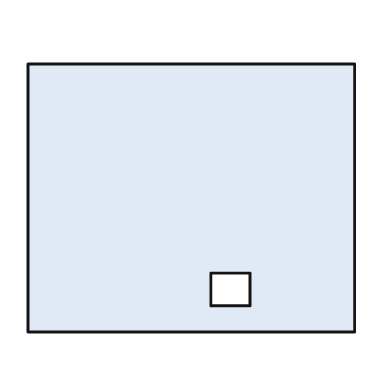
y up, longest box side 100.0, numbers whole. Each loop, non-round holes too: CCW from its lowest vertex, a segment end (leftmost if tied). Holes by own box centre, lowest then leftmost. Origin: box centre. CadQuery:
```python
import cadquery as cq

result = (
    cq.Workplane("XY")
    .moveTo(-50.0, -41.0)
    .lineTo(50.0, -41.0)
    .lineTo(50.0, 41.0)
    .lineTo(-50.0, 41.0)
    .close()
    .moveTo(6.0, -33.0)
    .lineTo(18.0, -33.0)
    .lineTo(18.0, -23.0)
    .lineTo(6.0, -23.0)
    .close()
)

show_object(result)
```